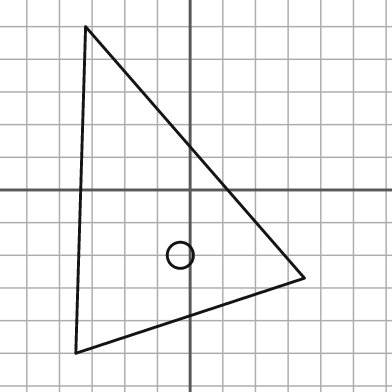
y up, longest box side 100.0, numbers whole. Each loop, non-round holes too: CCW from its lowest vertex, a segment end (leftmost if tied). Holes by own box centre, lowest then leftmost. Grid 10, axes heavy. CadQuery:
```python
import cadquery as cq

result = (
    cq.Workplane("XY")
    .moveTo(-35.0, -50.0)
    .lineTo(35.0, -27.0)
    .lineTo(-32.0, 50.0)
    .close()
    .moveTo(-3.0, -20.0)
    .circle(4.0)
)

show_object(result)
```